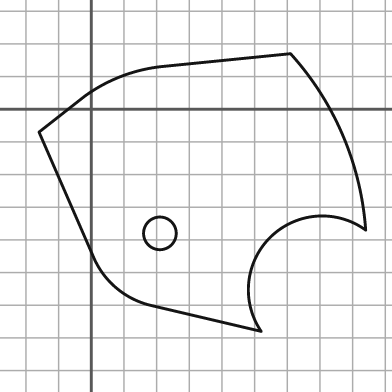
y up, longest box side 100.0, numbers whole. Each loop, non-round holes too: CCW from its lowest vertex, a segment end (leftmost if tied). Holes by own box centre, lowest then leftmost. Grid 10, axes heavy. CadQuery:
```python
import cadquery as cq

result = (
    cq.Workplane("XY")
    .moveTo(52.0, -68.0)
    .threePointArc((55.0, -39.0), (84.0, -37.0))
    .threePointArc((77.0, -8.0), (61.0, 17.0))
    .lineTo(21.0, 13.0)
    .threePointArc((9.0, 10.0), (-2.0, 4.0))
    .lineTo(-16.0, -7.0)
    .lineTo(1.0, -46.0)
    .threePointArc((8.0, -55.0), (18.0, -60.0))
    .close()
    .moveTo(21.0, -38.0)
    .circle(5.0)
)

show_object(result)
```